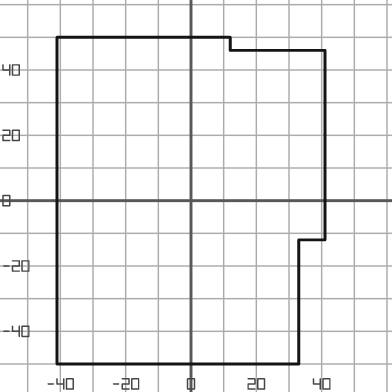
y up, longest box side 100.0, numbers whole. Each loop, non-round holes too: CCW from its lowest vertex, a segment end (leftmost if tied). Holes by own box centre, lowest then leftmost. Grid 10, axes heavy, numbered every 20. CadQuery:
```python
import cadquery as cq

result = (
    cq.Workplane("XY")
    .moveTo(-41.0, -50.0)
    .lineTo(33.0, -50.0)
    .lineTo(33.0, -12.0)
    .lineTo(41.0, -12.0)
    .lineTo(41.0, 46.0)
    .lineTo(12.0, 46.0)
    .lineTo(12.0, 50.0)
    .lineTo(-41.0, 50.0)
    .close()
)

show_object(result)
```